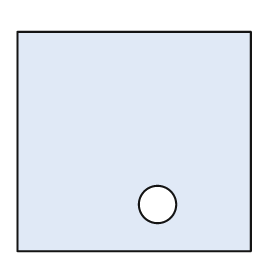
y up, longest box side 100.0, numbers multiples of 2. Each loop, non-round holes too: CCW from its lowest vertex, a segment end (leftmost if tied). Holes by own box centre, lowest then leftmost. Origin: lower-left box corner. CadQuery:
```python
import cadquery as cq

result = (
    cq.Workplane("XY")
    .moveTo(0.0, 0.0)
    .lineTo(100.0, 0.0)
    .lineTo(100.0, 94.0)
    .lineTo(0.0, 94.0)
    .close()
    .moveTo(60.0, 20.0)
    .circle(8.0)
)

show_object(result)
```